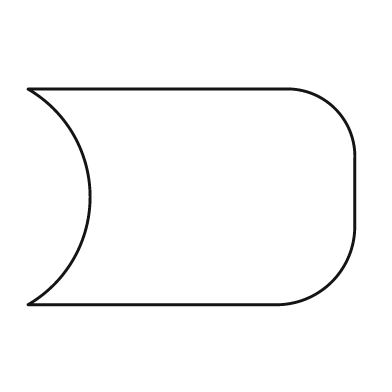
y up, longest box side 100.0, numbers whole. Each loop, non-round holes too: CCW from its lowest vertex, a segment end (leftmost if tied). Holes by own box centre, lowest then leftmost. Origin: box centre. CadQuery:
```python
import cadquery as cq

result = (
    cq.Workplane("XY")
    .moveTo(-50.0, -33.0)
    .lineTo(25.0, -33.0)
    .threePointArc((43.0, -26.0), (50.0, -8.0))
    .lineTo(50.0, 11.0)
    .threePointArc((44.0, 27.0), (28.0, 33.0))
    .lineTo(-50.0, 33.0)
    .threePointArc((-31.0, 0.0), (-50.0, -33.0))
    .close()
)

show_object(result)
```